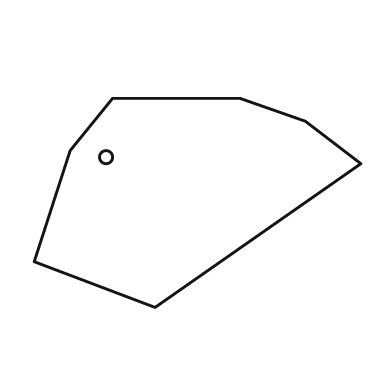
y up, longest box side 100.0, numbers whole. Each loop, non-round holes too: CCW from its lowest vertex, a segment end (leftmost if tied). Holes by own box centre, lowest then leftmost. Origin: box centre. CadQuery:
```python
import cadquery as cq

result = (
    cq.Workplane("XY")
    .moveTo(-13.0, -32.0)
    .lineTo(50.0, 12.0)
    .lineTo(33.0, 25.0)
    .lineTo(13.0, 32.0)
    .lineTo(-26.0, 32.0)
    .lineTo(-39.0, 16.0)
    .lineTo(-50.0, -18.0)
    .close()
    .moveTo(-28.0, 14.0)
    .circle(2.0)
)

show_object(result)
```